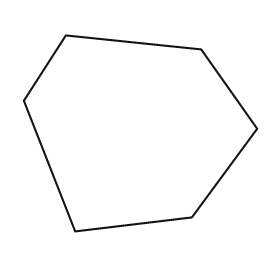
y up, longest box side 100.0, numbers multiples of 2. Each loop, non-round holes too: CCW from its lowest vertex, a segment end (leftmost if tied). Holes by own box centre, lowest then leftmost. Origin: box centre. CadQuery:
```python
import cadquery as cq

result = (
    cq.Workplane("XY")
    .moveTo(-28.0, -42.0)
    .lineTo(22.0, -36.0)
    .lineTo(50.0, 2.0)
    .lineTo(26.0, 36.0)
    .lineTo(-32.0, 42.0)
    .lineTo(-50.0, 14.0)
    .close()
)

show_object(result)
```